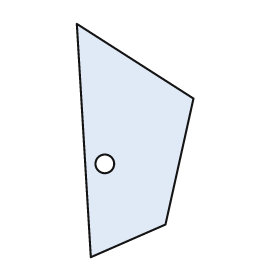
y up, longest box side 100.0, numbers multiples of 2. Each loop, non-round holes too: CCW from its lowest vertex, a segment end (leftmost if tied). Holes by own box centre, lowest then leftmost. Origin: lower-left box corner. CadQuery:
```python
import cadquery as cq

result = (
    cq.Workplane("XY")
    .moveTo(6.0, 0.0)
    .lineTo(38.0, 14.0)
    .lineTo(50.0, 68.0)
    .lineTo(0.0, 100.0)
    .close()
    .moveTo(12.0, 40.0)
    .circle(4.0)
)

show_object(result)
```